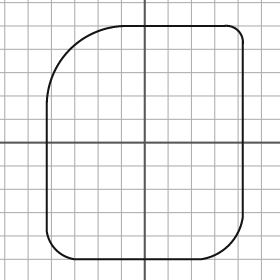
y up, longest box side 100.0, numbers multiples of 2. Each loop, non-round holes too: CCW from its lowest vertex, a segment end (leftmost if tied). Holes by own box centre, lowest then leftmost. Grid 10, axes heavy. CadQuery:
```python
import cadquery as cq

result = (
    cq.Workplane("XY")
    .moveTo(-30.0, -50.0)
    .lineTo(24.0, -50.0)
    .threePointArc((36.0, -44.0), (42.0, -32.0))
    .lineTo(42.0, 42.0)
    .threePointArc((40.0, 48.0), (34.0, 50.0))
    .lineTo(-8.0, 50.0)
    .threePointArc((-32.0, 40.0), (-42.0, 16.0))
    .lineTo(-42.0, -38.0)
    .threePointArc((-38.0, -46.0), (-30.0, -50.0))
    .close()
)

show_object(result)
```